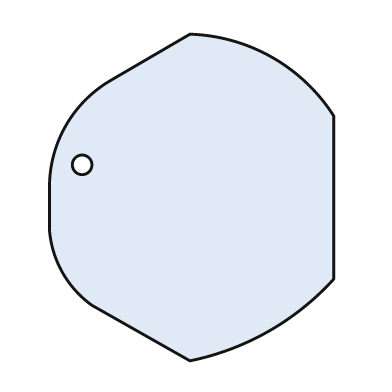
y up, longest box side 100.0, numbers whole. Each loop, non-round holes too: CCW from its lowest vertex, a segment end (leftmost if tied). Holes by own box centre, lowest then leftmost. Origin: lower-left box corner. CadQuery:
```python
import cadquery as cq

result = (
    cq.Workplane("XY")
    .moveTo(43.0, 0.0)
    .threePointArc((67.0, 9.0), (87.0, 25.0))
    .lineTo(87.0, 75.0)
    .threePointArc((68.0, 93.0), (43.0, 100.0))
    .lineTo(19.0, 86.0)
    .threePointArc((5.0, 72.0), (0.0, 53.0))
    .lineTo(0.0, 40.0)
    .threePointArc((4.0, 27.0), (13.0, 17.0))
    .close()
    .moveTo(10.0, 60.0)
    .circle(3.0)
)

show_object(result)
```